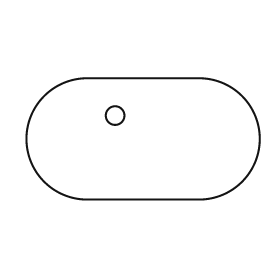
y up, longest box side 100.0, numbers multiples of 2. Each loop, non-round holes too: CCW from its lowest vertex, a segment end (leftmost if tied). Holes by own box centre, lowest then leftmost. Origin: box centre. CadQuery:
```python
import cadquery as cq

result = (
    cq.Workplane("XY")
    .moveTo(-24.0, -26.0)
    .lineTo(24.0, -26.0)
    .threePointArc((50.0, 0.0), (24.0, 26.0))
    .lineTo(-24.0, 26.0)
    .threePointArc((-50.0, 0.0), (-24.0, -26.0))
    .close()
    .moveTo(-12.0, 10.0)
    .circle(4.0)
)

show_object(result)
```